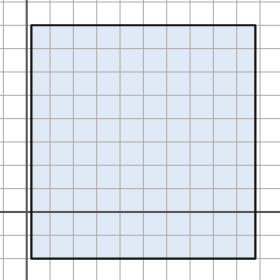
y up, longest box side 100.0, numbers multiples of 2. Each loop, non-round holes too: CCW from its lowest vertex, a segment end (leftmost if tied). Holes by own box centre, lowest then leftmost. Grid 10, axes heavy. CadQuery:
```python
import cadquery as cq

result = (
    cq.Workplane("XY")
    .moveTo(2.0, -20.0)
    .lineTo(98.0, -20.0)
    .lineTo(98.0, 80.0)
    .lineTo(2.0, 80.0)
    .close()
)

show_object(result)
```